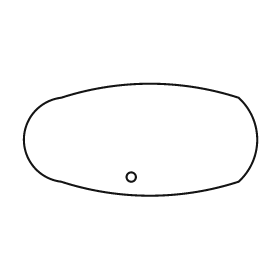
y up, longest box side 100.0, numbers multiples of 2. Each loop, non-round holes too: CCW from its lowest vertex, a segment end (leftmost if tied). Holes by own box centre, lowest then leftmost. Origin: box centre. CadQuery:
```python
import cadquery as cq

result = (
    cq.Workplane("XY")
    .moveTo(-34.0, -18.0)
    .threePointArc((4.0, -24.0), (42.0, -18.0))
    .threePointArc((50.0, 0.0), (42.0, 18.0))
    .threePointArc((4.0, 24.0), (-34.0, 18.0))
    .threePointArc((-50.0, 0.0), (-34.0, -18.0))
    .close()
    .moveTo(-4.0, -16.0)
    .circle(2.0)
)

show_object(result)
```